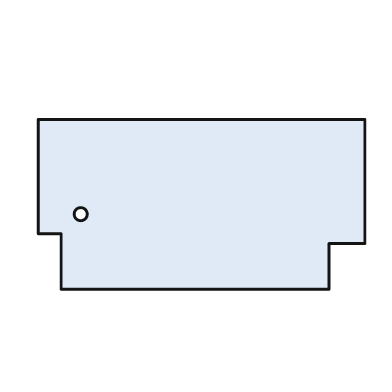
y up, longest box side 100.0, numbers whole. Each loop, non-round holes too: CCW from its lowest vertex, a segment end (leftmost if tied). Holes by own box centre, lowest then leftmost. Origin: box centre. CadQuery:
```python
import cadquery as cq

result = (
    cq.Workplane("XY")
    .moveTo(-43.0, -26.0)
    .lineTo(39.0, -26.0)
    .lineTo(39.0, -12.0)
    .lineTo(50.0, -12.0)
    .lineTo(50.0, 26.0)
    .lineTo(-50.0, 26.0)
    .lineTo(-50.0, -9.0)
    .lineTo(-43.0, -9.0)
    .close()
    .moveTo(-37.0, -3.0)
    .circle(2.0)
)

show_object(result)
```